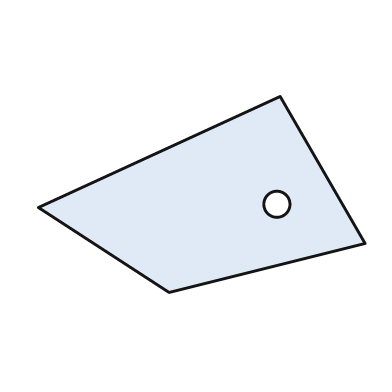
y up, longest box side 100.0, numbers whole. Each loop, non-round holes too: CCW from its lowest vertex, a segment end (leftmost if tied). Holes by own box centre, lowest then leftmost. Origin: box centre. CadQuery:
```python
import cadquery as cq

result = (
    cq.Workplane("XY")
    .moveTo(-10.0, -30.0)
    .lineTo(50.0, -15.0)
    .lineTo(24.0, 30.0)
    .lineTo(-50.0, -4.0)
    .close()
    .moveTo(23.0, -3.0)
    .circle(4.0)
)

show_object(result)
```